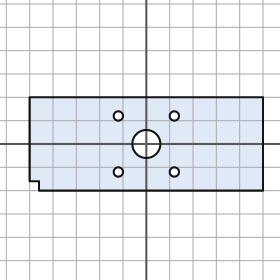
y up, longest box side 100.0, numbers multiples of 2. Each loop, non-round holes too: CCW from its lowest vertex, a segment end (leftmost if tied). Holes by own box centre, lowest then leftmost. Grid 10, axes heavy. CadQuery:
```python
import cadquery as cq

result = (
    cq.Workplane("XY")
    .moveTo(-46.0, -20.0)
    .lineTo(50.0, -20.0)
    .lineTo(50.0, 20.0)
    .lineTo(-50.0, 20.0)
    .lineTo(-50.0, -16.0)
    .lineTo(-46.0, -16.0)
    .close()
    .moveTo(-12.0, -12.0)
    .circle(2.0)
    .moveTo(12.0, -12.0)
    .circle(2.0)
    .moveTo(0.0, 0.0)
    .circle(6.0)
    .moveTo(-12.0, 12.0)
    .circle(2.0)
    .moveTo(12.0, 12.0)
    .circle(2.0)
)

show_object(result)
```